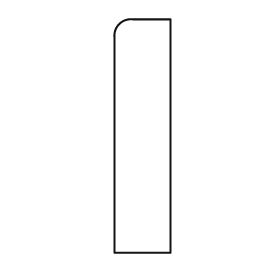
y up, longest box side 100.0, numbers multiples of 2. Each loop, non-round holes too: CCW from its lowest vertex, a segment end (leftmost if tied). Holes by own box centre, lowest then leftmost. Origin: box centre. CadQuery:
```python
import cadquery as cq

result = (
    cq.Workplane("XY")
    .moveTo(-12.0, -50.0)
    .lineTo(12.0, -50.0)
    .lineTo(12.0, 50.0)
    .lineTo(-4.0, 50.0)
    .threePointArc((-10.0, 48.0), (-12.0, 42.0))
    .close()
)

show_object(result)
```